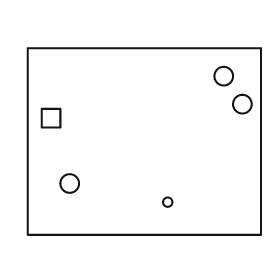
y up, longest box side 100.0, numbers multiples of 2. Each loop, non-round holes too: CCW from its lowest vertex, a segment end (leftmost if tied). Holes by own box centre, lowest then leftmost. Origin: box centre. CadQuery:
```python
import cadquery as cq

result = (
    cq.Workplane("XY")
    .moveTo(-50.0, -40.0)
    .lineTo(50.0, -40.0)
    .lineTo(50.0, 40.0)
    .lineTo(-50.0, 40.0)
    .close()
    .moveTo(10.0, -26.0)
    .circle(2.0)
    .moveTo(-32.0, -18.0)
    .circle(4.0)
    .moveTo(-44.0, 6.0)
    .lineTo(-36.0, 6.0)
    .lineTo(-36.0, 14.0)
    .lineTo(-44.0, 14.0)
    .close()
    .moveTo(42.0, 16.0)
    .circle(4.0)
    .moveTo(34.0, 28.0)
    .circle(4.0)
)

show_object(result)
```